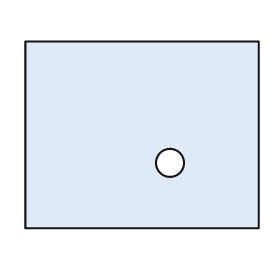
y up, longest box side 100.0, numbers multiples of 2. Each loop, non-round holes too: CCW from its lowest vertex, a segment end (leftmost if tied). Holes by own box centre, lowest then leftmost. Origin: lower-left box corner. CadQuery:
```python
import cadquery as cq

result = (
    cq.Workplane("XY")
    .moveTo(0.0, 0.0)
    .lineTo(100.0, 0.0)
    .lineTo(100.0, 80.0)
    .lineTo(0.0, 80.0)
    .close()
    .moveTo(62.0, 28.0)
    .circle(6.0)
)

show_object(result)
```